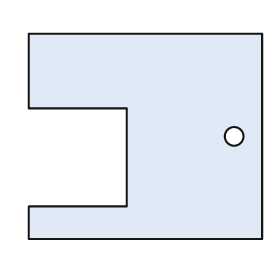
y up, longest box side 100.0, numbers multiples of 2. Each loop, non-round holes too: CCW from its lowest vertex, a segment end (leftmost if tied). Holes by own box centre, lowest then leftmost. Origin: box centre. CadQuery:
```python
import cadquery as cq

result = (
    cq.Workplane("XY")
    .moveTo(-50.0, -44.0)
    .lineTo(50.0, -44.0)
    .lineTo(50.0, 44.0)
    .lineTo(-50.0, 44.0)
    .lineTo(-50.0, 12.0)
    .lineTo(-8.0, 12.0)
    .lineTo(-8.0, -30.0)
    .lineTo(-50.0, -30.0)
    .close()
    .moveTo(38.0, 0.0)
    .circle(4.0)
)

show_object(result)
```